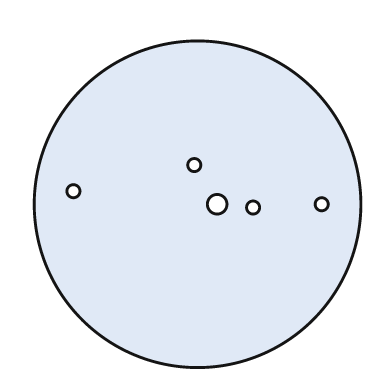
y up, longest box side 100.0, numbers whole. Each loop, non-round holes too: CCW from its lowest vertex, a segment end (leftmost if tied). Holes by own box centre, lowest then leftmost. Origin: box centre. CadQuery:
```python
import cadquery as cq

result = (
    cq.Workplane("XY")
    .moveTo(0.0, 0.0)
    .circle(50.0)
    .moveTo(17.0, -1.0)
    .circle(2.0)
    .moveTo(6.0, 0.0)
    .circle(3.0)
    .moveTo(38.0, 0.0)
    .circle(2.0)
    .moveTo(-38.0, 4.0)
    .circle(2.0)
    .moveTo(-1.0, 12.0)
    .circle(2.0)
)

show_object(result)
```